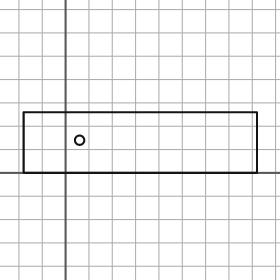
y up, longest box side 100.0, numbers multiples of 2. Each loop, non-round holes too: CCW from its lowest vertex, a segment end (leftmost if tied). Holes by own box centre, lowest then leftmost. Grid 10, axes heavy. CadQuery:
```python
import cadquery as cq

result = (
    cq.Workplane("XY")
    .moveTo(-18.0, 0.0)
    .lineTo(82.0, 0.0)
    .lineTo(82.0, 26.0)
    .lineTo(-18.0, 26.0)
    .close()
    .moveTo(6.0, 14.0)
    .circle(2.0)
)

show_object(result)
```